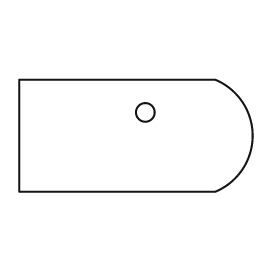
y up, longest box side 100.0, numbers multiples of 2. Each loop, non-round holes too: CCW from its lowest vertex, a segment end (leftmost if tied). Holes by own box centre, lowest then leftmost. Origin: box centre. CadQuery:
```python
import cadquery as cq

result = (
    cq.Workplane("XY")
    .moveTo(-50.0, -24.0)
    .lineTo(34.0, -24.0)
    .threePointArc((50.0, 0.0), (34.0, 24.0))
    .lineTo(-50.0, 24.0)
    .close()
    .moveTo(4.0, 10.0)
    .circle(4.0)
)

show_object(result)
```